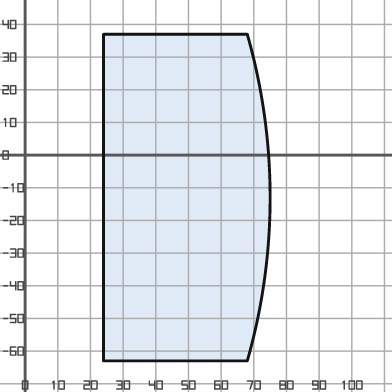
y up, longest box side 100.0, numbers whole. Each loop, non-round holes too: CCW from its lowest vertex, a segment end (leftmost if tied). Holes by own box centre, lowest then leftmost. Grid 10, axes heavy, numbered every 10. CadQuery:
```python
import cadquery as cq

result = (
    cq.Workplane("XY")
    .moveTo(24.0, -63.0)
    .lineTo(68.0, -63.0)
    .threePointArc((75.0, -13.0), (68.0, 37.0))
    .lineTo(24.0, 37.0)
    .close()
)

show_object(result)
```